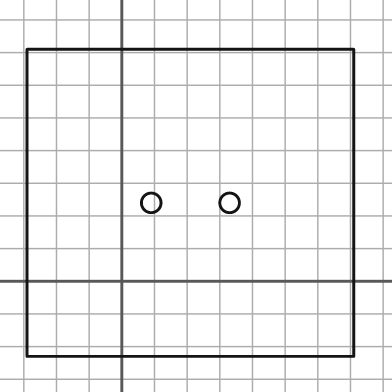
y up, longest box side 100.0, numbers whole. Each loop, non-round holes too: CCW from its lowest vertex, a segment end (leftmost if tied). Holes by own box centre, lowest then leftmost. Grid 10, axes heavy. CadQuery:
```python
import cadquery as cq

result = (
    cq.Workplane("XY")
    .moveTo(-29.0, -23.0)
    .lineTo(71.0, -23.0)
    .lineTo(71.0, 71.0)
    .lineTo(-29.0, 71.0)
    .close()
    .moveTo(9.0, 24.0)
    .circle(3.0)
    .moveTo(33.0, 24.0)
    .circle(3.0)
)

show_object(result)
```